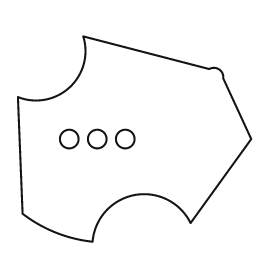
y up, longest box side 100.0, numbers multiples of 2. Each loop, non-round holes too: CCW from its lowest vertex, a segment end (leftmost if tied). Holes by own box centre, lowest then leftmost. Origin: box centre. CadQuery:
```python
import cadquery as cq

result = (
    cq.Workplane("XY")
    .moveTo(-18.0, -44.0)
    .threePointArc((0.0, -24.0), (24.0, -36.0))
    .lineTo(50.0, 0.0)
    .lineTo(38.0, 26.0)
    .threePointArc((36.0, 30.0), (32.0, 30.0))
    .lineTo(-22.0, 44.0)
    .threePointArc((-28.0, 22.0), (-50.0, 18.0))
    .lineTo(-48.0, -32.0)
    .threePointArc((-34.0, -40.0), (-18.0, -44.0))
    .close()
    .moveTo(-28.0, 0.0)
    .circle(4.0)
    .moveTo(-16.0, 0.0)
    .circle(4.0)
    .moveTo(-4.0, 0.0)
    .circle(4.0)
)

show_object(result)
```